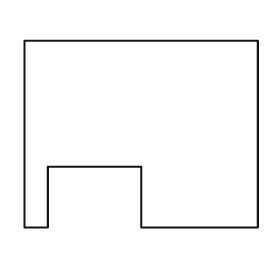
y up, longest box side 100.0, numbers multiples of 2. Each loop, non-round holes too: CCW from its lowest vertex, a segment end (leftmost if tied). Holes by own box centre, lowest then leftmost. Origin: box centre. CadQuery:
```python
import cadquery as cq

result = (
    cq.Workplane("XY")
    .moveTo(-50.0, -40.0)
    .lineTo(-40.0, -40.0)
    .lineTo(-40.0, -14.0)
    .lineTo(0.0, -14.0)
    .lineTo(0.0, -40.0)
    .lineTo(50.0, -40.0)
    .lineTo(50.0, 40.0)
    .lineTo(-50.0, 40.0)
    .close()
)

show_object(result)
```